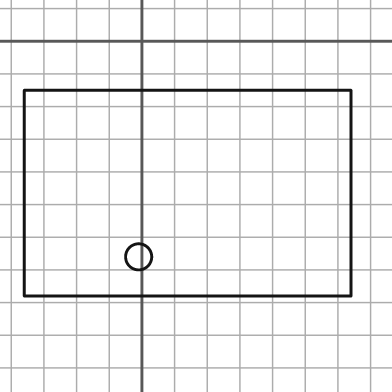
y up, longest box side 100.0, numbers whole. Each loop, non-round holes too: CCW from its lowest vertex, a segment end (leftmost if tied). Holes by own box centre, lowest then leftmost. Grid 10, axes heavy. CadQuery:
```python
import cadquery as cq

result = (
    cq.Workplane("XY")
    .moveTo(-36.0, -78.0)
    .lineTo(64.0, -78.0)
    .lineTo(64.0, -15.0)
    .lineTo(-36.0, -15.0)
    .close()
    .moveTo(-1.0, -66.0)
    .circle(4.0)
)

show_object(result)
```